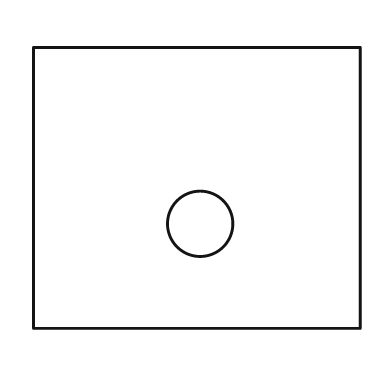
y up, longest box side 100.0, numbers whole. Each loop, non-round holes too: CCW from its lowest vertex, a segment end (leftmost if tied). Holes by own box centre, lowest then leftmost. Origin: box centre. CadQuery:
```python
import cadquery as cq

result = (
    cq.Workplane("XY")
    .moveTo(-50.0, -43.0)
    .lineTo(50.0, -43.0)
    .lineTo(50.0, 43.0)
    .lineTo(-50.0, 43.0)
    .close()
    .moveTo(1.0, -11.0)
    .circle(10.0)
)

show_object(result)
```